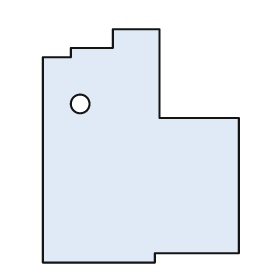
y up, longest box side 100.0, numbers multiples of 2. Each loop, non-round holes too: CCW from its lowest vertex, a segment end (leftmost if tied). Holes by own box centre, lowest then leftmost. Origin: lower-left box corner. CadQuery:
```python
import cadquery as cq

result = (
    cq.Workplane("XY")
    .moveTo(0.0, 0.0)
    .lineTo(48.0, 0.0)
    .lineTo(48.0, 4.0)
    .lineTo(84.0, 4.0)
    .lineTo(84.0, 62.0)
    .lineTo(50.0, 62.0)
    .lineTo(50.0, 100.0)
    .lineTo(30.0, 100.0)
    .lineTo(30.0, 92.0)
    .lineTo(12.0, 92.0)
    .lineTo(12.0, 88.0)
    .lineTo(0.0, 88.0)
    .close()
    .moveTo(16.0, 68.0)
    .circle(4.0)
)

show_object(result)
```